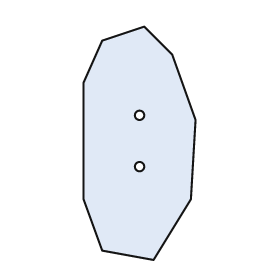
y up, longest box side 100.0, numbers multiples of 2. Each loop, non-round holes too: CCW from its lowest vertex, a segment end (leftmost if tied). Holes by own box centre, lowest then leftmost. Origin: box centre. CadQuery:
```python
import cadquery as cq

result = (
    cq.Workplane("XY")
    .moveTo(6.0, -50.0)
    .lineTo(22.0, -24.0)
    .lineTo(24.0, 10.0)
    .lineTo(14.0, 38.0)
    .lineTo(2.0, 50.0)
    .lineTo(-16.0, 44.0)
    .lineTo(-24.0, 26.0)
    .lineTo(-24.0, -24.0)
    .lineTo(-16.0, -46.0)
    .close()
    .moveTo(0.0, -10.0)
    .circle(2.0)
    .moveTo(0.0, 12.0)
    .circle(2.0)
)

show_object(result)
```